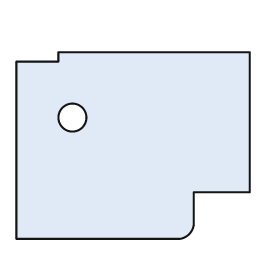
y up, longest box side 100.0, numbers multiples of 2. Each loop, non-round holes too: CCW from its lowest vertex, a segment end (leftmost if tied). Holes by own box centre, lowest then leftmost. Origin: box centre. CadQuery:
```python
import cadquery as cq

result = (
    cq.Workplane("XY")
    .moveTo(-50.0, -40.0)
    .lineTo(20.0, -40.0)
    .threePointArc((24.0, -38.0), (26.0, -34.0))
    .lineTo(26.0, -20.0)
    .lineTo(50.0, -20.0)
    .lineTo(50.0, 40.0)
    .lineTo(-32.0, 40.0)
    .lineTo(-32.0, 36.0)
    .lineTo(-50.0, 36.0)
    .close()
    .moveTo(-26.0, 12.0)
    .circle(6.0)
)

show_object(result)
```